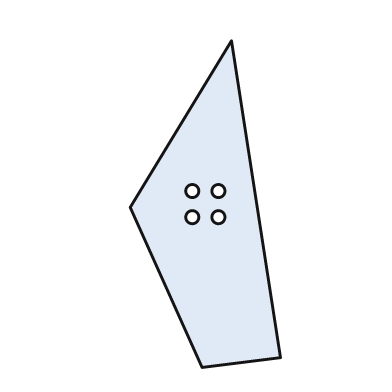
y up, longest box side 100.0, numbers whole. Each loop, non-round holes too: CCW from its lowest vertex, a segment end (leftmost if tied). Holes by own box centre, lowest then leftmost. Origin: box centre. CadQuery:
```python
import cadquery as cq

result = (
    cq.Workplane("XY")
    .moveTo(-1.0, -50.0)
    .lineTo(23.0, -47.0)
    .lineTo(8.0, 50.0)
    .lineTo(-23.0, -1.0)
    .close()
    .moveTo(-4.0, -4.0)
    .circle(2.0)
    .moveTo(4.0, -4.0)
    .circle(2.0)
    .moveTo(-4.0, 4.0)
    .circle(2.0)
    .moveTo(4.0, 4.0)
    .circle(2.0)
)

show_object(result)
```